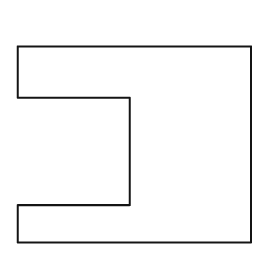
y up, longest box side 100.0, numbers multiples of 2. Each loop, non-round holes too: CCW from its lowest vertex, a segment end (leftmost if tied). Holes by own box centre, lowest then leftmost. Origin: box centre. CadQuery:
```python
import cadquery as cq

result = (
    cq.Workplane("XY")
    .moveTo(-50.0, -42.0)
    .lineTo(50.0, -42.0)
    .lineTo(50.0, 42.0)
    .lineTo(-50.0, 42.0)
    .lineTo(-50.0, 20.0)
    .lineTo(-2.0, 20.0)
    .lineTo(-2.0, -26.0)
    .lineTo(-50.0, -26.0)
    .close()
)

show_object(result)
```